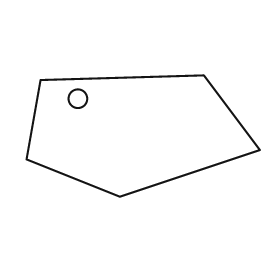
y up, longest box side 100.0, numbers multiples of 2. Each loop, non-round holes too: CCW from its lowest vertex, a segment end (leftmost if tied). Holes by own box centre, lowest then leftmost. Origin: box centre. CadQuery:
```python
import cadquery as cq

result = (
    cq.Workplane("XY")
    .moveTo(-10.0, -26.0)
    .lineTo(50.0, -6.0)
    .lineTo(26.0, 26.0)
    .lineTo(-44.0, 24.0)
    .lineTo(-50.0, -10.0)
    .close()
    .moveTo(-28.0, 16.0)
    .circle(4.0)
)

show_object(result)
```